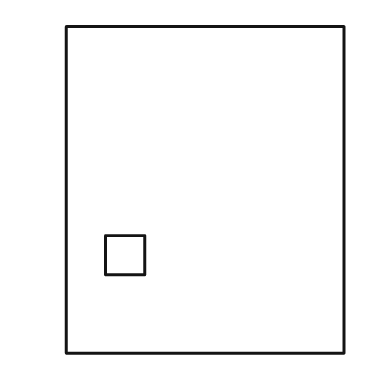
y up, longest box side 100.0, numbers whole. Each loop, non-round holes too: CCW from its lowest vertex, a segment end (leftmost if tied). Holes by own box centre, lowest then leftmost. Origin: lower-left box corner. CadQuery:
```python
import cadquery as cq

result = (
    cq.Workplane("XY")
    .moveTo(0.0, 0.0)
    .lineTo(85.0, 0.0)
    .lineTo(85.0, 100.0)
    .lineTo(0.0, 100.0)
    .close()
    .moveTo(12.0, 24.0)
    .lineTo(24.0, 24.0)
    .lineTo(24.0, 36.0)
    .lineTo(12.0, 36.0)
    .close()
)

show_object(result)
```